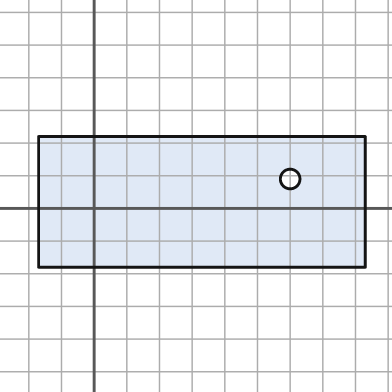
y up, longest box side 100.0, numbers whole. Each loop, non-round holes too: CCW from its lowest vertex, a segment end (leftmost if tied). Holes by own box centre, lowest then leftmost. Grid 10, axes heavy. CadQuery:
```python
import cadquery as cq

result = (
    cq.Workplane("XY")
    .moveTo(-17.0, -18.0)
    .lineTo(83.0, -18.0)
    .lineTo(83.0, 22.0)
    .lineTo(-17.0, 22.0)
    .close()
    .moveTo(60.0, 9.0)
    .circle(3.0)
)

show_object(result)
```